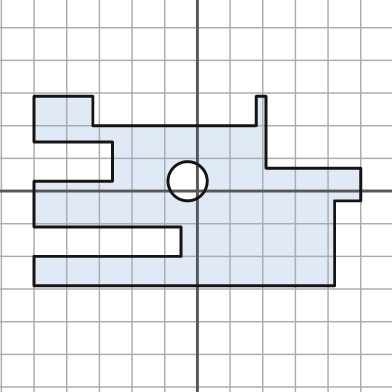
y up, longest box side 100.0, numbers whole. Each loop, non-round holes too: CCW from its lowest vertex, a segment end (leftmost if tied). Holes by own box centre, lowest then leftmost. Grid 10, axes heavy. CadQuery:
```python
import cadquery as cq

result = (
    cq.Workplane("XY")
    .moveTo(-50.0, -29.0)
    .lineTo(42.0, -29.0)
    .lineTo(42.0, -3.0)
    .lineTo(50.0, -3.0)
    .lineTo(50.0, 7.0)
    .lineTo(21.0, 7.0)
    .lineTo(21.0, 29.0)
    .lineTo(18.0, 29.0)
    .lineTo(18.0, 20.0)
    .lineTo(-32.0, 20.0)
    .lineTo(-32.0, 29.0)
    .lineTo(-50.0, 29.0)
    .lineTo(-50.0, 15.0)
    .lineTo(-26.0, 15.0)
    .lineTo(-26.0, 3.0)
    .lineTo(-50.0, 3.0)
    .lineTo(-50.0, -11.0)
    .lineTo(-5.0, -11.0)
    .lineTo(-5.0, -20.0)
    .lineTo(-50.0, -20.0)
    .close()
    .moveTo(-3.0, 3.0)
    .circle(6.0)
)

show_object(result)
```